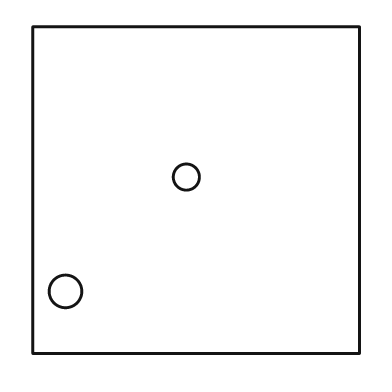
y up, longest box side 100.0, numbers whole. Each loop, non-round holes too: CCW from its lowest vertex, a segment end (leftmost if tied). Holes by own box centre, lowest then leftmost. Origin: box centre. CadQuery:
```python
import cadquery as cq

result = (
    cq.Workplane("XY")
    .moveTo(-50.0, -50.0)
    .lineTo(50.0, -50.0)
    .lineTo(50.0, 50.0)
    .lineTo(-50.0, 50.0)
    .close()
    .moveTo(-40.0, -31.0)
    .circle(5.0)
    .moveTo(-3.0, 4.0)
    .circle(4.0)
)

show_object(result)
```